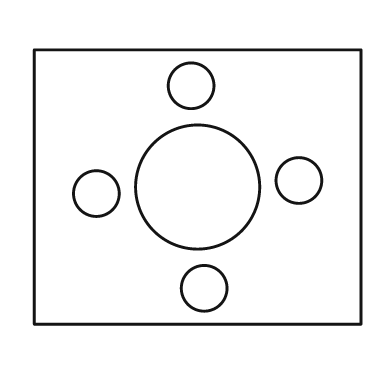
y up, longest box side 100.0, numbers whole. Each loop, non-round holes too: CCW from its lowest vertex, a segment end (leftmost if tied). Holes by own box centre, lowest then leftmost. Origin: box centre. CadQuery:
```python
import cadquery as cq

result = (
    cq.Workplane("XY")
    .moveTo(-50.0, -42.0)
    .lineTo(50.0, -42.0)
    .lineTo(50.0, 42.0)
    .lineTo(-50.0, 42.0)
    .close()
    .moveTo(2.0, -31.0)
    .circle(7.0)
    .moveTo(-31.0, -2.0)
    .circle(7.0)
    .moveTo(0.0, 0.0)
    .circle(19.0)
    .moveTo(31.0, 2.0)
    .circle(7.0)
    .moveTo(-2.0, 31.0)
    .circle(7.0)
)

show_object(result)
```